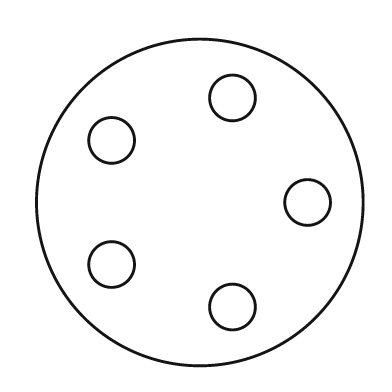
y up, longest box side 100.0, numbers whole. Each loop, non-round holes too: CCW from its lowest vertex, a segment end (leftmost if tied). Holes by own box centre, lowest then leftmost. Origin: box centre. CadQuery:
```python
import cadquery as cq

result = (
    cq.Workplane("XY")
    .moveTo(0.0, 0.0)
    .circle(50.0)
    .moveTo(10.0, -32.0)
    .circle(7.0)
    .moveTo(-27.0, -19.0)
    .circle(7.0)
    .moveTo(33.0, 0.0)
    .circle(7.0)
    .moveTo(-27.0, 19.0)
    .circle(7.0)
    .moveTo(10.0, 32.0)
    .circle(7.0)
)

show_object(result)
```